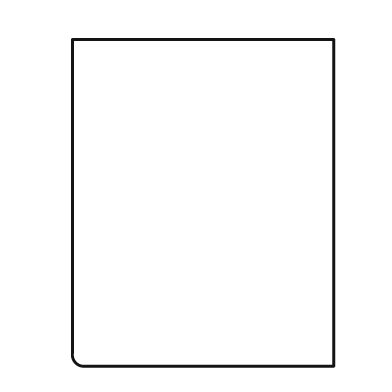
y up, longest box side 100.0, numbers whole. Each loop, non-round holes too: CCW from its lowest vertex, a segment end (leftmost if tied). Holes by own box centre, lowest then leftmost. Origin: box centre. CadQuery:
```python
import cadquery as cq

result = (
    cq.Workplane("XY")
    .moveTo(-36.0, -50.0)
    .lineTo(40.0, -50.0)
    .lineTo(40.0, 50.0)
    .lineTo(-40.0, 50.0)
    .lineTo(-40.0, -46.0)
    .threePointArc((-39.0, -49.0), (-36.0, -50.0))
    .close()
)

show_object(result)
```